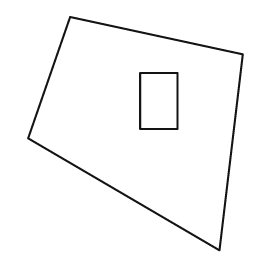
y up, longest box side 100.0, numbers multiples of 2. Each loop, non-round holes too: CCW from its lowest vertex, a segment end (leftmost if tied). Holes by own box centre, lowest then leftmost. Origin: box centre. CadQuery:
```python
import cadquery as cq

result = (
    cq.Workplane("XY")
    .moveTo(36.0, -50.0)
    .lineTo(46.0, 34.0)
    .lineTo(-28.0, 50.0)
    .lineTo(-46.0, -2.0)
    .close()
    .moveTo(2.0, 2.0)
    .lineTo(18.0, 2.0)
    .lineTo(18.0, 26.0)
    .lineTo(2.0, 26.0)
    .close()
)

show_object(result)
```